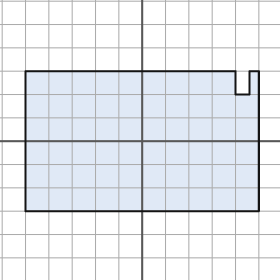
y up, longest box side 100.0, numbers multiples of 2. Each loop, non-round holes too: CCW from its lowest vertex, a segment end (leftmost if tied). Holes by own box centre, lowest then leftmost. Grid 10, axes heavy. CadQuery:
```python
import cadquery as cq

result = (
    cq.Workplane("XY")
    .moveTo(-50.0, -30.0)
    .lineTo(50.0, -30.0)
    .lineTo(50.0, 30.0)
    .lineTo(46.0, 30.0)
    .lineTo(46.0, 20.0)
    .lineTo(40.0, 20.0)
    .lineTo(40.0, 30.0)
    .lineTo(-50.0, 30.0)
    .close()
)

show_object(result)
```